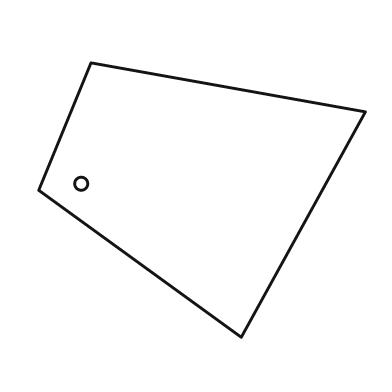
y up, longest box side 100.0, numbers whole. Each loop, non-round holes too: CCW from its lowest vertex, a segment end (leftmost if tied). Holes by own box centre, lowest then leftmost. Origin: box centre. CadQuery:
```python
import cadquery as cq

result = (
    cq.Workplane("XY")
    .moveTo(12.0, -42.0)
    .lineTo(50.0, 27.0)
    .lineTo(-34.0, 42.0)
    .lineTo(-50.0, 3.0)
    .close()
    .moveTo(-37.0, 5.0)
    .circle(2.0)
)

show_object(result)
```